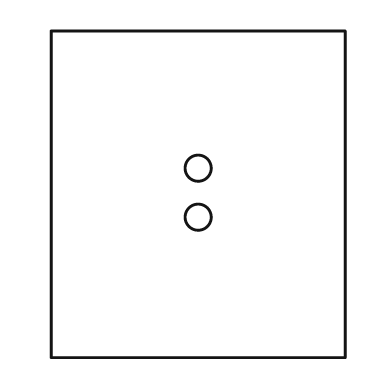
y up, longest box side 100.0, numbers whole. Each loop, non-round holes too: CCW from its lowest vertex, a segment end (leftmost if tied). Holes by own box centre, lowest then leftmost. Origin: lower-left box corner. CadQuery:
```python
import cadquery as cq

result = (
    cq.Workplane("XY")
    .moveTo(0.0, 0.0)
    .lineTo(90.0, 0.0)
    .lineTo(90.0, 100.0)
    .lineTo(0.0, 100.0)
    .close()
    .moveTo(45.0, 43.0)
    .circle(4.0)
    .moveTo(45.0, 58.0)
    .circle(4.0)
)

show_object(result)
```